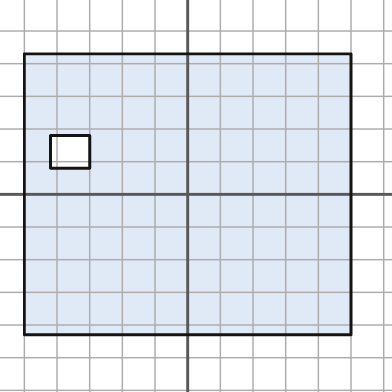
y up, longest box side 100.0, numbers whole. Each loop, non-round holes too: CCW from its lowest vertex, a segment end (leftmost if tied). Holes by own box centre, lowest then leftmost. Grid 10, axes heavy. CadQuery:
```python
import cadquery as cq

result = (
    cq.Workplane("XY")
    .moveTo(-50.0, -43.0)
    .lineTo(50.0, -43.0)
    .lineTo(50.0, 43.0)
    .lineTo(-50.0, 43.0)
    .close()
    .moveTo(-42.0, 8.0)
    .lineTo(-30.0, 8.0)
    .lineTo(-30.0, 18.0)
    .lineTo(-42.0, 18.0)
    .close()
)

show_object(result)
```